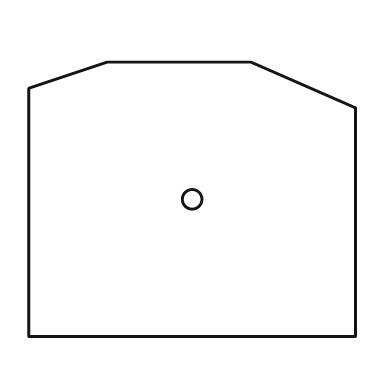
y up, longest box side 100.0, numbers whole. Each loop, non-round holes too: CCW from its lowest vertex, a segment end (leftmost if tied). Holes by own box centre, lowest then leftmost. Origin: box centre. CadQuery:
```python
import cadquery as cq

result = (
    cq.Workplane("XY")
    .moveTo(-50.0, -42.0)
    .lineTo(50.0, -42.0)
    .lineTo(50.0, 28.0)
    .lineTo(18.0, 42.0)
    .lineTo(-26.0, 42.0)
    .lineTo(-50.0, 34.0)
    .close()
    .moveTo(0.0, 0.0)
    .circle(3.0)
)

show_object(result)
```